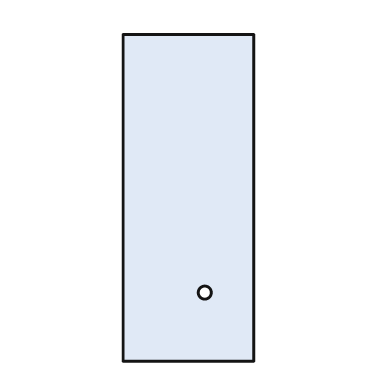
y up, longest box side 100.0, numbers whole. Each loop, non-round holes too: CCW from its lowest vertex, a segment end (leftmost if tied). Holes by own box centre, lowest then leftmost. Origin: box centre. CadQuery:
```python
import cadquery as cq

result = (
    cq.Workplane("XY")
    .moveTo(-20.0, -50.0)
    .lineTo(20.0, -50.0)
    .lineTo(20.0, 50.0)
    .lineTo(-20.0, 50.0)
    .close()
    .moveTo(5.0, -29.0)
    .circle(2.0)
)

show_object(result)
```